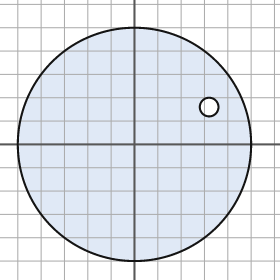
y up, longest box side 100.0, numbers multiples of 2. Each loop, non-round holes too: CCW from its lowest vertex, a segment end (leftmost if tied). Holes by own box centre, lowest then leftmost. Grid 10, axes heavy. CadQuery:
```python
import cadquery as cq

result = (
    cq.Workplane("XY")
    .moveTo(0.0, 0.0)
    .circle(50.0)
    .moveTo(32.0, 16.0)
    .circle(4.0)
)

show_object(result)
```